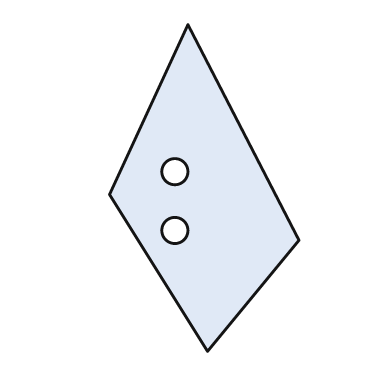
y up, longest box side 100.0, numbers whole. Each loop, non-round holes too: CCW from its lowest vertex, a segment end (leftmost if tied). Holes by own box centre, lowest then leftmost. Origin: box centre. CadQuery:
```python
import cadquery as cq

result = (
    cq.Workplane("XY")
    .moveTo(1.0, -50.0)
    .lineTo(29.0, -16.0)
    .lineTo(-5.0, 50.0)
    .lineTo(-29.0, -2.0)
    .close()
    .moveTo(-9.0, -13.0)
    .circle(4.0)
    .moveTo(-9.0, 5.0)
    .circle(4.0)
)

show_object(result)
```